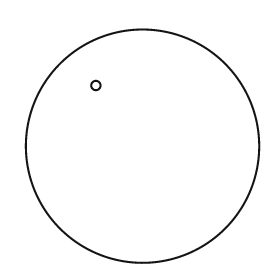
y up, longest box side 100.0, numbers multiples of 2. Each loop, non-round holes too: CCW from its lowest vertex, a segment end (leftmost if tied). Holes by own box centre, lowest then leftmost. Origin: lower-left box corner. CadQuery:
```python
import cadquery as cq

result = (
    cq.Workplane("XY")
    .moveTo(50.0, 50.0)
    .circle(50.0)
    .moveTo(30.0, 76.0)
    .circle(2.0)
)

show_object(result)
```